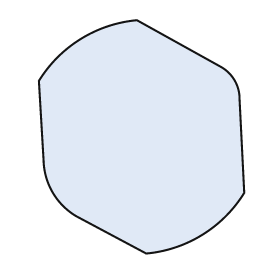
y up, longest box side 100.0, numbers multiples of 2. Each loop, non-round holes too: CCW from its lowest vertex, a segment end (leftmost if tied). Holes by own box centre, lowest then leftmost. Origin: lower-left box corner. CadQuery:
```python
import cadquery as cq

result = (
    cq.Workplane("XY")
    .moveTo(46.0, 0.0)
    .threePointArc((70.0, 8.0), (88.0, 26.0))
    .lineTo(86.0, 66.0)
    .threePointArc((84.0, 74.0), (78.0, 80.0))
    .lineTo(42.0, 100.0)
    .threePointArc((18.0, 92.0), (0.0, 74.0))
    .lineTo(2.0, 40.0)
    .threePointArc((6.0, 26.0), (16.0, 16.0))
    .close()
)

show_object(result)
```